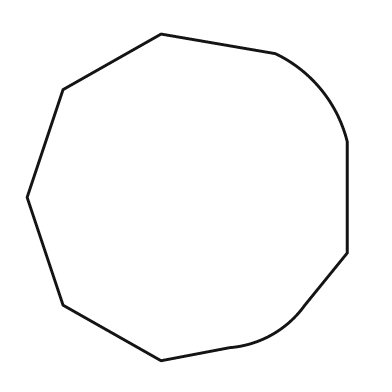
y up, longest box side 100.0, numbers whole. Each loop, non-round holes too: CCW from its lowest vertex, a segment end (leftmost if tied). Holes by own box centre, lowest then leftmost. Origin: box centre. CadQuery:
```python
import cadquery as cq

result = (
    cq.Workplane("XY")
    .moveTo(-8.0, -50.0)
    .lineTo(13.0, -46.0)
    .threePointArc((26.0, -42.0), (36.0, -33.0))
    .lineTo(49.0, -17.0)
    .lineTo(49.0, 17.0)
    .threePointArc((41.0, 33.0), (27.0, 44.0))
    .lineTo(-8.0, 50.0)
    .lineTo(-38.0, 33.0)
    .lineTo(-49.0, 0.0)
    .lineTo(-38.0, -33.0)
    .close()
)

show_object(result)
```